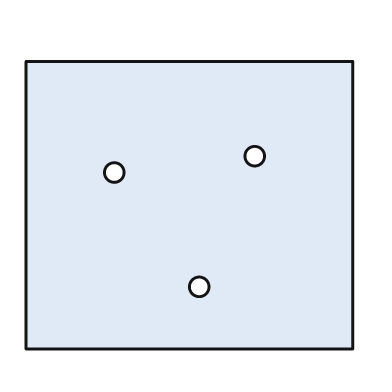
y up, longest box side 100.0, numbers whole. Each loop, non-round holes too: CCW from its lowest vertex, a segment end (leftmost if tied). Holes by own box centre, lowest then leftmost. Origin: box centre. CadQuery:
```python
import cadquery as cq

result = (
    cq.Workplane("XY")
    .moveTo(-50.0, -44.0)
    .lineTo(50.0, -44.0)
    .lineTo(50.0, 44.0)
    .lineTo(-50.0, 44.0)
    .close()
    .moveTo(3.0, -25.0)
    .circle(3.0)
    .moveTo(-23.0, 10.0)
    .circle(3.0)
    .moveTo(20.0, 15.0)
    .circle(3.0)
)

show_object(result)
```